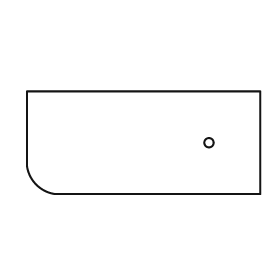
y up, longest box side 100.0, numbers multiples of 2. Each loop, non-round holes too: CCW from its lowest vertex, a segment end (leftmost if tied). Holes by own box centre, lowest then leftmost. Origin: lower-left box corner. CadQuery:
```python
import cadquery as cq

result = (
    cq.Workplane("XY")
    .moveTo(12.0, 0.0)
    .lineTo(100.0, 0.0)
    .lineTo(100.0, 44.0)
    .lineTo(0.0, 44.0)
    .lineTo(0.0, 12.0)
    .threePointArc((4.0, 4.0), (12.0, 0.0))
    .close()
    .moveTo(78.0, 22.0)
    .circle(2.0)
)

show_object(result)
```